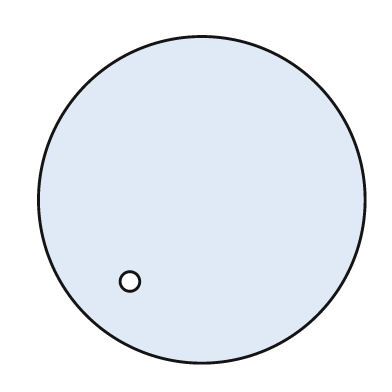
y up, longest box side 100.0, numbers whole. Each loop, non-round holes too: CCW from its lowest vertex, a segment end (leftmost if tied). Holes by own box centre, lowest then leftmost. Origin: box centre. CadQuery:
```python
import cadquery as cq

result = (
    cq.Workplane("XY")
    .moveTo(0.0, 0.0)
    .circle(50.0)
    .moveTo(-22.0, -25.0)
    .circle(3.0)
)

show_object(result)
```